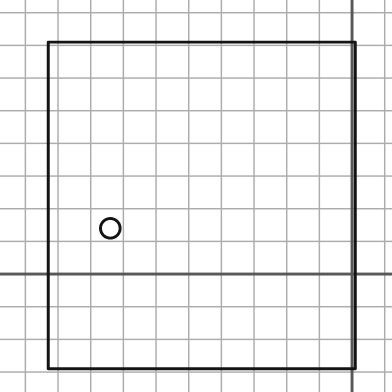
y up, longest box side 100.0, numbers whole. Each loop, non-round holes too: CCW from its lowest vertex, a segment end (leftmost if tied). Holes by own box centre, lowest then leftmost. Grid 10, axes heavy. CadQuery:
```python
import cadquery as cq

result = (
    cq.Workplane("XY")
    .moveTo(-93.0, -29.0)
    .lineTo(1.0, -29.0)
    .lineTo(1.0, 71.0)
    .lineTo(-93.0, 71.0)
    .close()
    .moveTo(-74.0, 14.0)
    .circle(3.0)
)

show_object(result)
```